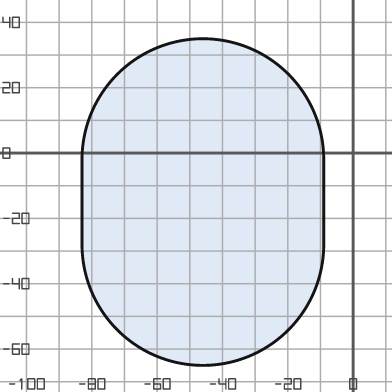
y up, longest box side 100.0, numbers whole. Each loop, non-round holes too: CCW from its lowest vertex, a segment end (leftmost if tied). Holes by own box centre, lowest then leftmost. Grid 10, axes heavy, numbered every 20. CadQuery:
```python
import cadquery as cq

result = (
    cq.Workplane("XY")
    .moveTo(-83.0, -28.0)
    .threePointArc((-46.0, -65.0), (-9.0, -28.0))
    .lineTo(-9.0, -2.0)
    .threePointArc((-46.0, 35.0), (-83.0, -2.0))
    .close()
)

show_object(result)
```